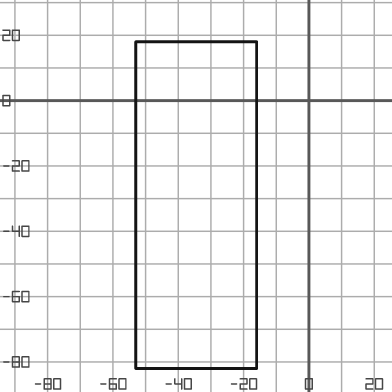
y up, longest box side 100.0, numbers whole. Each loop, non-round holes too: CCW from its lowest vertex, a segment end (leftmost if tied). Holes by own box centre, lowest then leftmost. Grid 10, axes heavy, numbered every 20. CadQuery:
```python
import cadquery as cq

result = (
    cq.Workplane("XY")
    .moveTo(-53.0, -82.0)
    .lineTo(-16.0, -82.0)
    .lineTo(-16.0, 18.0)
    .lineTo(-53.0, 18.0)
    .close()
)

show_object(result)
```